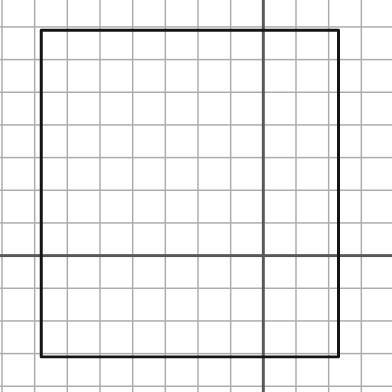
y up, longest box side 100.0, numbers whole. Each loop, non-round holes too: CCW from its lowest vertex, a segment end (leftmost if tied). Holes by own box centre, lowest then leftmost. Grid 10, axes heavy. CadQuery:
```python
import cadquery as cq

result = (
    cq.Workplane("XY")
    .moveTo(-68.0, -31.0)
    .lineTo(23.0, -31.0)
    .lineTo(23.0, 69.0)
    .lineTo(-68.0, 69.0)
    .close()
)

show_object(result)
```